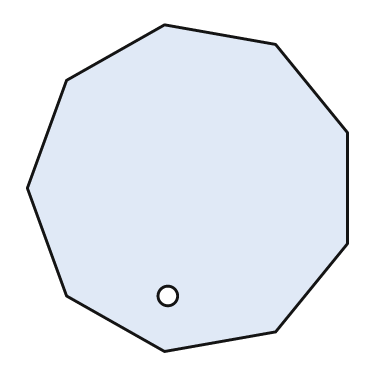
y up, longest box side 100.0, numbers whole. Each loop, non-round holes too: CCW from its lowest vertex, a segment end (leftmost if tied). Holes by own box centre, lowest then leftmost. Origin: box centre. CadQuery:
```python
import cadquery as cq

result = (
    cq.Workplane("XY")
    .moveTo(-7.0, -50.0)
    .lineTo(27.0, -44.0)
    .lineTo(49.0, -17.0)
    .lineTo(49.0, 17.0)
    .lineTo(27.0, 44.0)
    .lineTo(-7.0, 50.0)
    .lineTo(-37.0, 33.0)
    .lineTo(-49.0, 0.0)
    .lineTo(-37.0, -33.0)
    .close()
    .moveTo(-6.0, -33.0)
    .circle(3.0)
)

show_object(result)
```